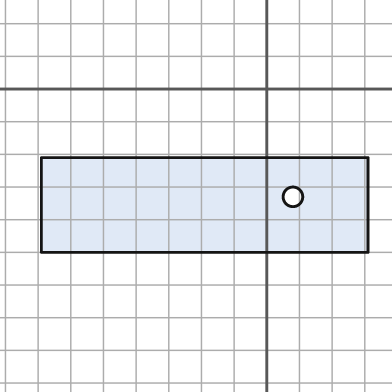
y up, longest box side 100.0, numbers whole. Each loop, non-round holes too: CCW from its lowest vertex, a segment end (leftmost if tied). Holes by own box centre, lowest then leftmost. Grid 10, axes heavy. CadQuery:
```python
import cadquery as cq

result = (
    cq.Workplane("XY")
    .moveTo(-69.0, -50.0)
    .lineTo(31.0, -50.0)
    .lineTo(31.0, -21.0)
    .lineTo(-69.0, -21.0)
    .close()
    .moveTo(8.0, -33.0)
    .circle(3.0)
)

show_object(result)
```